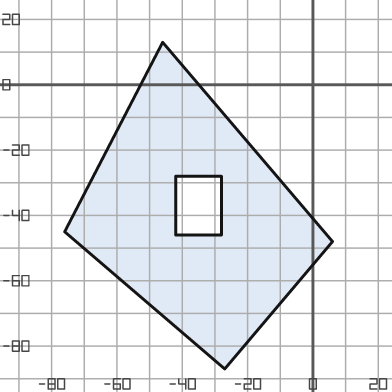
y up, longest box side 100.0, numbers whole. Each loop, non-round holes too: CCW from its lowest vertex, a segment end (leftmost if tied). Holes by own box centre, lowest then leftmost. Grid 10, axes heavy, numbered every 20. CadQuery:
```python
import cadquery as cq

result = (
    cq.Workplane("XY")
    .moveTo(-27.0, -87.0)
    .lineTo(6.0, -48.0)
    .lineTo(-46.0, 13.0)
    .lineTo(-76.0, -45.0)
    .close()
    .moveTo(-42.0, -46.0)
    .lineTo(-28.0, -46.0)
    .lineTo(-28.0, -28.0)
    .lineTo(-42.0, -28.0)
    .close()
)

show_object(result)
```